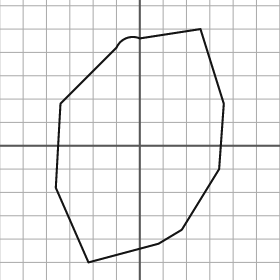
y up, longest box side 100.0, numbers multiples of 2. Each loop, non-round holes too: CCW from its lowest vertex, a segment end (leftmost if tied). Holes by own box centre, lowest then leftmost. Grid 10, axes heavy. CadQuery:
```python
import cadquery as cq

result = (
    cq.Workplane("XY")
    .moveTo(-22.0, -50.0)
    .lineTo(8.0, -42.0)
    .lineTo(18.0, -36.0)
    .lineTo(34.0, -10.0)
    .lineTo(36.0, 18.0)
    .lineTo(26.0, 50.0)
    .lineTo(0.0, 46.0)
    .threePointArc((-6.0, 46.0), (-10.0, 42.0))
    .lineTo(-34.0, 18.0)
    .lineTo(-36.0, -18.0)
    .close()
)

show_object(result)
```